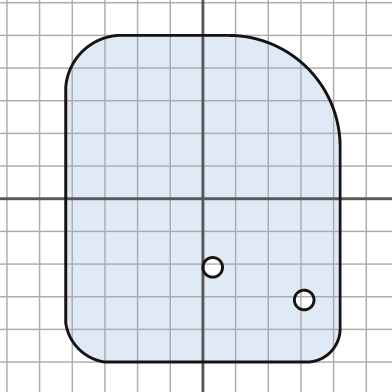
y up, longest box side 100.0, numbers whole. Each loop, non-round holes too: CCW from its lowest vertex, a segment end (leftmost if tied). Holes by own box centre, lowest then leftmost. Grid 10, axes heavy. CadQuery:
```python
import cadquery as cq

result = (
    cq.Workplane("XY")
    .moveTo(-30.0, -50.0)
    .lineTo(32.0, -50.0)
    .threePointArc((39.0, -47.0), (42.0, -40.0))
    .lineTo(42.0, 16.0)
    .threePointArc((32.0, 40.0), (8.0, 50.0))
    .lineTo(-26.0, 50.0)
    .threePointArc((-37.0, 45.0), (-42.0, 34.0))
    .lineTo(-42.0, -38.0)
    .threePointArc((-38.0, -46.0), (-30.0, -50.0))
    .close()
    .moveTo(31.0, -31.0)
    .circle(3.0)
    .moveTo(3.0, -21.0)
    .circle(3.0)
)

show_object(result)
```